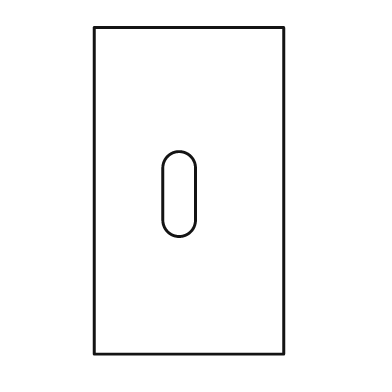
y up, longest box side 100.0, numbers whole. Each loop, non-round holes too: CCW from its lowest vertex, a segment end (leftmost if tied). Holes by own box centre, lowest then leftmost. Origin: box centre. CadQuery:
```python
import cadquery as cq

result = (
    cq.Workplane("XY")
    .moveTo(-29.0, -50.0)
    .lineTo(29.0, -50.0)
    .lineTo(29.0, 50.0)
    .lineTo(-29.0, 50.0)
    .close()
    .moveTo(-8.0, -9.0)
    .threePointArc((-3.0, -14.0), (2.0, -9.0))
    .lineTo(2.0, 7.0)
    .threePointArc((-3.0, 12.0), (-8.0, 7.0))
    .close()
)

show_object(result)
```